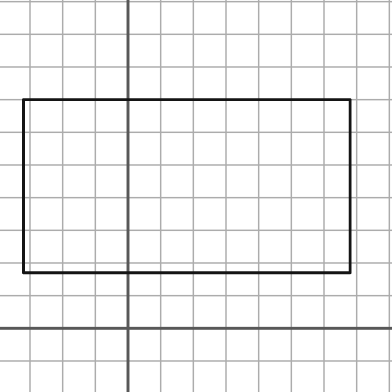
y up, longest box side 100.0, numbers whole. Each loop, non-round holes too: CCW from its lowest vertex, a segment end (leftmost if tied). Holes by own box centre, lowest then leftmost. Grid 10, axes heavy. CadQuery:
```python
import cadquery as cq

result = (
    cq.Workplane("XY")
    .moveTo(-32.0, 17.0)
    .lineTo(68.0, 17.0)
    .lineTo(68.0, 70.0)
    .lineTo(-32.0, 70.0)
    .close()
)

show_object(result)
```